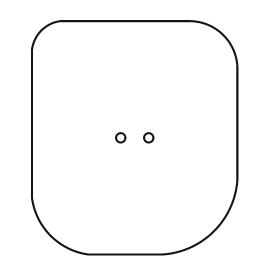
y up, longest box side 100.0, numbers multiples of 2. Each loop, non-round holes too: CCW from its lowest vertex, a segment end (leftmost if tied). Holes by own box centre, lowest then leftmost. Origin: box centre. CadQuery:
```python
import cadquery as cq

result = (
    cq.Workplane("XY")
    .moveTo(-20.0, -50.0)
    .lineTo(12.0, -50.0)
    .threePointArc((34.0, -40.0), (44.0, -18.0))
    .lineTo(44.0, 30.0)
    .threePointArc((38.0, 44.0), (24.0, 50.0))
    .lineTo(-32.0, 50.0)
    .threePointArc((-40.0, 46.0), (-44.0, 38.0))
    .lineTo(-44.0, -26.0)
    .threePointArc((-36.0, -42.0), (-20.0, -50.0))
    .close()
    .moveTo(-6.0, 0.0)
    .circle(2.0)
    .moveTo(6.0, 0.0)
    .circle(2.0)
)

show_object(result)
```